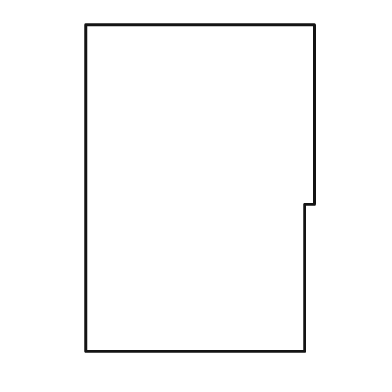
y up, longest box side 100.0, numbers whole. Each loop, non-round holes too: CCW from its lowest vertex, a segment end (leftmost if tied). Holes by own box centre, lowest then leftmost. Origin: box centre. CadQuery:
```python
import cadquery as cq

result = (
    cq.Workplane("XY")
    .moveTo(-35.0, -50.0)
    .lineTo(32.0, -50.0)
    .lineTo(32.0, -5.0)
    .lineTo(35.0, -5.0)
    .lineTo(35.0, 50.0)
    .lineTo(-35.0, 50.0)
    .close()
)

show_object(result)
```